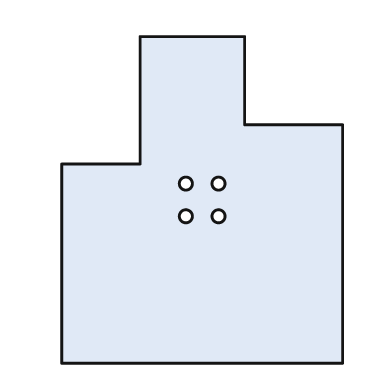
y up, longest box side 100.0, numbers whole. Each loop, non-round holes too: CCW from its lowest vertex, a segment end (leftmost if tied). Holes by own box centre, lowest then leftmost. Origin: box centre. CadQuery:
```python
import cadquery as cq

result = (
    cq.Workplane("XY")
    .moveTo(-43.0, -50.0)
    .lineTo(43.0, -50.0)
    .lineTo(43.0, 23.0)
    .lineTo(13.0, 23.0)
    .lineTo(13.0, 50.0)
    .lineTo(-19.0, 50.0)
    .lineTo(-19.0, 11.0)
    .lineTo(-43.0, 11.0)
    .close()
    .moveTo(-5.0, -5.0)
    .circle(2.0)
    .moveTo(5.0, -5.0)
    .circle(2.0)
    .moveTo(-5.0, 5.0)
    .circle(2.0)
    .moveTo(5.0, 5.0)
    .circle(2.0)
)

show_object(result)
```